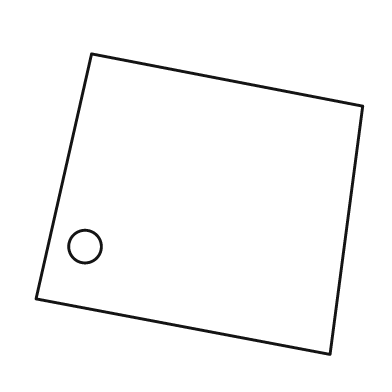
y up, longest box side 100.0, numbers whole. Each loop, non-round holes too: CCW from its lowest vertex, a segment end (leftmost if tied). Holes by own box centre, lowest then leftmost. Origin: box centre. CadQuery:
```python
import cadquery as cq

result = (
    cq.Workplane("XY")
    .moveTo(40.0, -46.0)
    .lineTo(50.0, 30.0)
    .lineTo(-33.0, 46.0)
    .lineTo(-50.0, -29.0)
    .close()
    .moveTo(-35.0, -13.0)
    .circle(5.0)
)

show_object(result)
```